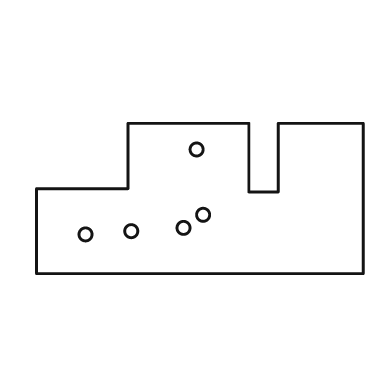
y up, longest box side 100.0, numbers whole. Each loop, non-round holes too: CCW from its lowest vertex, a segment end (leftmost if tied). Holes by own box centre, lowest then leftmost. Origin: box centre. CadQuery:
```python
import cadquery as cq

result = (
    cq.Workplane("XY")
    .moveTo(-50.0, -23.0)
    .lineTo(50.0, -23.0)
    .lineTo(50.0, 23.0)
    .lineTo(24.0, 23.0)
    .lineTo(24.0, 2.0)
    .lineTo(15.0, 2.0)
    .lineTo(15.0, 23.0)
    .lineTo(-22.0, 23.0)
    .lineTo(-22.0, 3.0)
    .lineTo(-50.0, 3.0)
    .close()
    .moveTo(-35.0, -11.0)
    .circle(2.0)
    .moveTo(-21.0, -10.0)
    .circle(2.0)
    .moveTo(-5.0, -9.0)
    .circle(2.0)
    .moveTo(1.0, -5.0)
    .circle(2.0)
    .moveTo(-1.0, 15.0)
    .circle(2.0)
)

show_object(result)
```